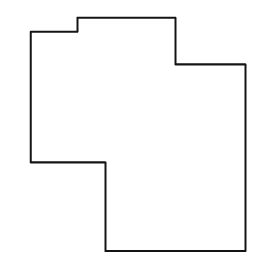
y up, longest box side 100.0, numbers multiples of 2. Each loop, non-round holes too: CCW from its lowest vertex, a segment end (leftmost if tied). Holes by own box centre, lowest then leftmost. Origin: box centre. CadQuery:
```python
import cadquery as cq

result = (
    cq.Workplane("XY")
    .moveTo(-14.0, -50.0)
    .lineTo(46.0, -50.0)
    .lineTo(46.0, 30.0)
    .lineTo(16.0, 30.0)
    .lineTo(16.0, 50.0)
    .lineTo(-26.0, 50.0)
    .lineTo(-26.0, 44.0)
    .lineTo(-46.0, 44.0)
    .lineTo(-46.0, -12.0)
    .lineTo(-14.0, -12.0)
    .close()
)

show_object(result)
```